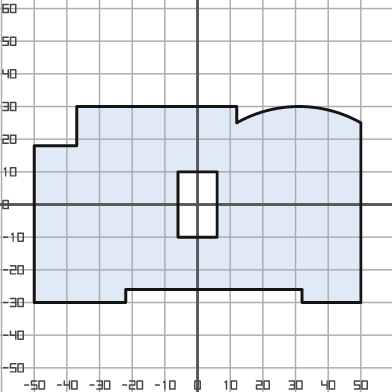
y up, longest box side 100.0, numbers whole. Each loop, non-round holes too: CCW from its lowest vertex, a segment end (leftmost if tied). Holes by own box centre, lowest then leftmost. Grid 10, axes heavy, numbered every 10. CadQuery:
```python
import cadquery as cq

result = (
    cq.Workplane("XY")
    .moveTo(-50.0, -30.0)
    .lineTo(-22.0, -30.0)
    .lineTo(-22.0, -26.0)
    .lineTo(32.0, -26.0)
    .lineTo(32.0, -30.0)
    .lineTo(50.0, -30.0)
    .lineTo(50.0, 25.0)
    .threePointArc((31.0, 30.0), (12.0, 25.0))
    .lineTo(12.0, 30.0)
    .lineTo(-37.0, 30.0)
    .lineTo(-37.0, 18.0)
    .lineTo(-50.0, 18.0)
    .close()
    .moveTo(-6.0, -10.0)
    .lineTo(6.0, -10.0)
    .lineTo(6.0, 10.0)
    .lineTo(-6.0, 10.0)
    .close()
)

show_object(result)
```